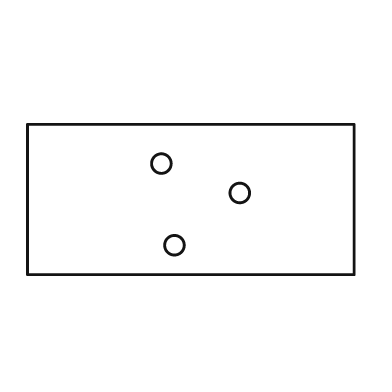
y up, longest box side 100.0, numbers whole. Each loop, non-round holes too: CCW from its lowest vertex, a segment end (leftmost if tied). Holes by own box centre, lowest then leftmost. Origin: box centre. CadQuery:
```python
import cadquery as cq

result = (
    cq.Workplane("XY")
    .moveTo(-50.0, -23.0)
    .lineTo(50.0, -23.0)
    .lineTo(50.0, 23.0)
    .lineTo(-50.0, 23.0)
    .close()
    .moveTo(-5.0, -14.0)
    .circle(3.0)
    .moveTo(15.0, 2.0)
    .circle(3.0)
    .moveTo(-9.0, 11.0)
    .circle(3.0)
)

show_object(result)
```